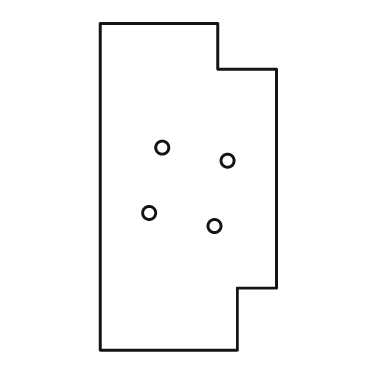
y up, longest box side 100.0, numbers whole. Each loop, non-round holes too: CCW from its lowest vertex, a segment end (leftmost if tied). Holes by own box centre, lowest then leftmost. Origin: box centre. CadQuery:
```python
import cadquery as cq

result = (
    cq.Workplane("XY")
    .moveTo(-27.0, -50.0)
    .lineTo(15.0, -50.0)
    .lineTo(15.0, -31.0)
    .lineTo(27.0, -31.0)
    .lineTo(27.0, 36.0)
    .lineTo(9.0, 36.0)
    .lineTo(9.0, 50.0)
    .lineTo(-27.0, 50.0)
    .close()
    .moveTo(8.0, -12.0)
    .circle(2.0)
    .moveTo(-12.0, -8.0)
    .circle(2.0)
    .moveTo(12.0, 8.0)
    .circle(2.0)
    .moveTo(-8.0, 12.0)
    .circle(2.0)
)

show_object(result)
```